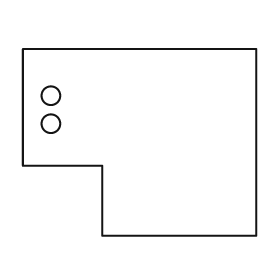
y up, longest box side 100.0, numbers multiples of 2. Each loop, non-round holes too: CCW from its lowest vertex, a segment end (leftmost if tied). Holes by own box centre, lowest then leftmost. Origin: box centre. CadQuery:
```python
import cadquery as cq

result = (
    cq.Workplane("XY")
    .moveTo(-16.0, -40.0)
    .lineTo(50.0, -40.0)
    .lineTo(50.0, 40.0)
    .lineTo(-50.0, 40.0)
    .lineTo(-50.0, -10.0)
    .lineTo(-16.0, -10.0)
    .close()
    .moveTo(-38.0, 8.0)
    .circle(4.0)
    .moveTo(-38.0, 20.0)
    .circle(4.0)
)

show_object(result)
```